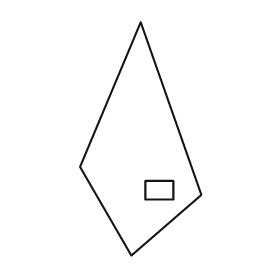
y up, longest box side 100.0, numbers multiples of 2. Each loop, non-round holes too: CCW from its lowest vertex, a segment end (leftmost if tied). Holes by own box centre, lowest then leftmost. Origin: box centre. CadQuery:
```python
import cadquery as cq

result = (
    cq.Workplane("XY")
    .moveTo(-4.0, -50.0)
    .lineTo(26.0, -24.0)
    .lineTo(0.0, 50.0)
    .lineTo(-26.0, -12.0)
    .close()
    .moveTo(2.0, -26.0)
    .lineTo(14.0, -26.0)
    .lineTo(14.0, -18.0)
    .lineTo(2.0, -18.0)
    .close()
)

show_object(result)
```